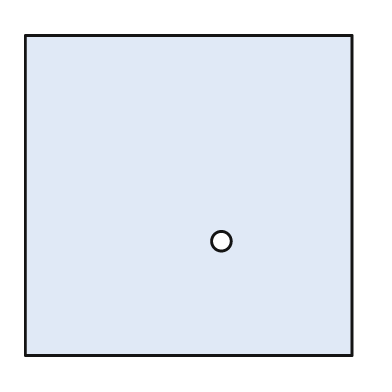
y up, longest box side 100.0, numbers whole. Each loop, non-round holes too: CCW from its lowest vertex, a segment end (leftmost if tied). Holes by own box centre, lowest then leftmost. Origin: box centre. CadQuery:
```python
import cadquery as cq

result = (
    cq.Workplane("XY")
    .moveTo(-50.0, -49.0)
    .lineTo(50.0, -49.0)
    .lineTo(50.0, 49.0)
    .lineTo(-50.0, 49.0)
    .close()
    .moveTo(10.0, -14.0)
    .circle(3.0)
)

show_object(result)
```